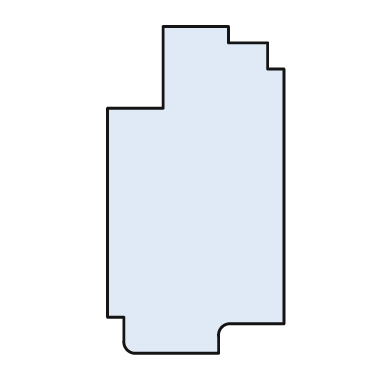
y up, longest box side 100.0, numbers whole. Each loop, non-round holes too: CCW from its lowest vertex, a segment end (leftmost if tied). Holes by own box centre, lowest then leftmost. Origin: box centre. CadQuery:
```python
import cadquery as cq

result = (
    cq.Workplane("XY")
    .moveTo(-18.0, -50.0)
    .lineTo(7.0, -50.0)
    .lineTo(7.0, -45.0)
    .threePointArc((8.0, -42.0), (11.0, -41.0))
    .lineTo(27.0, -41.0)
    .lineTo(27.0, 37.0)
    .lineTo(22.0, 37.0)
    .lineTo(22.0, 45.0)
    .lineTo(10.0, 45.0)
    .lineTo(10.0, 50.0)
    .lineTo(-10.0, 50.0)
    .lineTo(-10.0, 25.0)
    .lineTo(-27.0, 25.0)
    .lineTo(-27.0, -39.0)
    .lineTo(-22.0, -39.0)
    .lineTo(-22.0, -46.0)
    .threePointArc((-21.0, -49.0), (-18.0, -50.0))
    .close()
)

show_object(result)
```